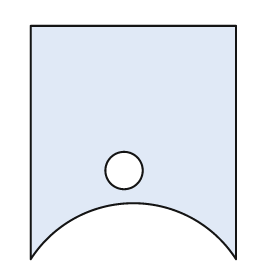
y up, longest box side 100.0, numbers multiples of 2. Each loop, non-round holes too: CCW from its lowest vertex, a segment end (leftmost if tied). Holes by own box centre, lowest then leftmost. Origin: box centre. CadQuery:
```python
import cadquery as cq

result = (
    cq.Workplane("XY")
    .moveTo(-44.0, -50.0)
    .threePointArc((0.0, -26.0), (44.0, -50.0))
    .lineTo(44.0, 50.0)
    .lineTo(-44.0, 50.0)
    .close()
    .moveTo(-4.0, -12.0)
    .circle(8.0)
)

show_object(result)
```